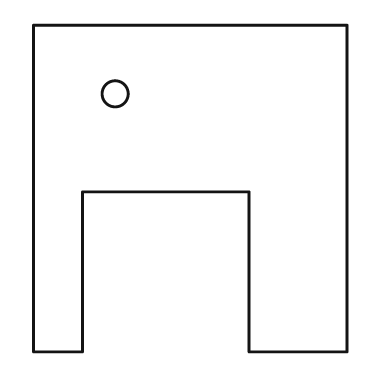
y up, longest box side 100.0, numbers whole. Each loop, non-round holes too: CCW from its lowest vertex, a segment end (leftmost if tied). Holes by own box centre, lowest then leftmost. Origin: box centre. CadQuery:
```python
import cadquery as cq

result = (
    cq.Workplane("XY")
    .moveTo(-48.0, -50.0)
    .lineTo(-33.0, -50.0)
    .lineTo(-33.0, -1.0)
    .lineTo(18.0, -1.0)
    .lineTo(18.0, -50.0)
    .lineTo(48.0, -50.0)
    .lineTo(48.0, 50.0)
    .lineTo(-48.0, 50.0)
    .close()
    .moveTo(-23.0, 29.0)
    .circle(4.0)
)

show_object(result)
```